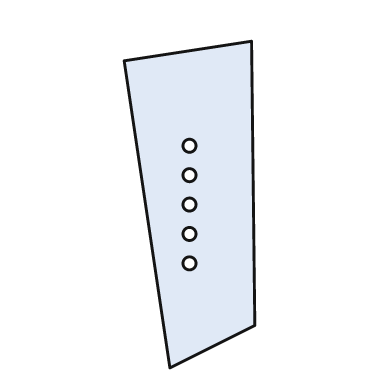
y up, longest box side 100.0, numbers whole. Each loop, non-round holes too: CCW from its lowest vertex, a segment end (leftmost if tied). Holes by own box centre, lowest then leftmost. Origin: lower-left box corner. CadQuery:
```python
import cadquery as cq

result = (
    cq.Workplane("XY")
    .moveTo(14.0, 0.0)
    .lineTo(40.0, 13.0)
    .lineTo(39.0, 100.0)
    .lineTo(0.0, 94.0)
    .close()
    .moveTo(20.0, 32.0)
    .circle(2.0)
    .moveTo(20.0, 41.0)
    .circle(2.0)
    .moveTo(20.0, 50.0)
    .circle(2.0)
    .moveTo(20.0, 59.0)
    .circle(2.0)
    .moveTo(20.0, 68.0)
    .circle(2.0)
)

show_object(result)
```